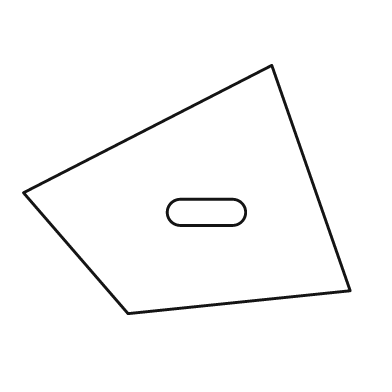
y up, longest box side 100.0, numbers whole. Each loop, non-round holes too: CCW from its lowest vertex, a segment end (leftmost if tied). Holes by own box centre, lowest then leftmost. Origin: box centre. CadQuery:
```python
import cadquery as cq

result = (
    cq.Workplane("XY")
    .moveTo(-18.0, -38.0)
    .lineTo(50.0, -31.0)
    .lineTo(26.0, 38.0)
    .lineTo(-50.0, -1.0)
    .close()
    .moveTo(-2.0, -11.0)
    .lineTo(14.0, -11.0)
    .threePointArc((18.0, -7.0), (14.0, -3.0))
    .lineTo(-2.0, -3.0)
    .threePointArc((-6.0, -7.0), (-2.0, -11.0))
    .close()
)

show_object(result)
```